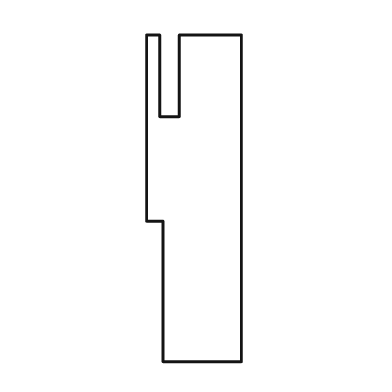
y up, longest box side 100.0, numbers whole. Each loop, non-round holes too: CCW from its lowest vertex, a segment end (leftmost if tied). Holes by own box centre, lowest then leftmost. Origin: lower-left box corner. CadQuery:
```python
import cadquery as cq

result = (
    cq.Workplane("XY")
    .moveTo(5.0, 0.0)
    .lineTo(29.0, 0.0)
    .lineTo(29.0, 100.0)
    .lineTo(10.0, 100.0)
    .lineTo(10.0, 75.0)
    .lineTo(4.0, 75.0)
    .lineTo(4.0, 100.0)
    .lineTo(0.0, 100.0)
    .lineTo(0.0, 43.0)
    .lineTo(5.0, 43.0)
    .close()
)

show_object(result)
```